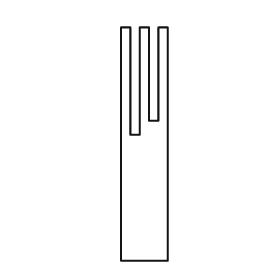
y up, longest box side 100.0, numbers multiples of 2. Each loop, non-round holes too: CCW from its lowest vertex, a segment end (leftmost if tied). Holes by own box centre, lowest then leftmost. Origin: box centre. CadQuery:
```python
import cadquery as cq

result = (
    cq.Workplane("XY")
    .moveTo(-10.0, -50.0)
    .lineTo(10.0, -50.0)
    .lineTo(10.0, 50.0)
    .lineTo(6.0, 50.0)
    .lineTo(6.0, 10.0)
    .lineTo(2.0, 10.0)
    .lineTo(2.0, 50.0)
    .lineTo(-2.0, 50.0)
    .lineTo(-2.0, 4.0)
    .lineTo(-6.0, 4.0)
    .lineTo(-6.0, 50.0)
    .lineTo(-10.0, 50.0)
    .close()
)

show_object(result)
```